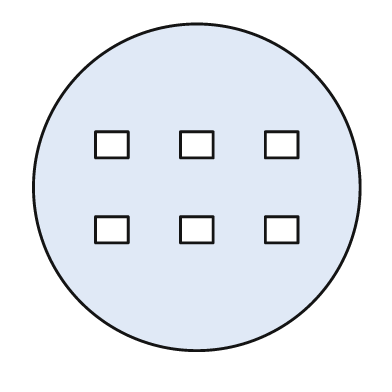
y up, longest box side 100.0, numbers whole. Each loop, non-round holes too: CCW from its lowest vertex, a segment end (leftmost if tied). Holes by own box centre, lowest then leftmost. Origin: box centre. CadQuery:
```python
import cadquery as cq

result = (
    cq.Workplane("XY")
    .moveTo(0.0, 0.0)
    .circle(50.0)
    .moveTo(-31.0, -17.0)
    .lineTo(-21.0, -17.0)
    .lineTo(-21.0, -9.0)
    .lineTo(-31.0, -9.0)
    .close()
    .moveTo(-5.0, -17.0)
    .lineTo(5.0, -17.0)
    .lineTo(5.0, -9.0)
    .lineTo(-5.0, -9.0)
    .close()
    .moveTo(21.0, -17.0)
    .lineTo(31.0, -17.0)
    .lineTo(31.0, -9.0)
    .lineTo(21.0, -9.0)
    .close()
    .moveTo(-31.0, 9.0)
    .lineTo(-21.0, 9.0)
    .lineTo(-21.0, 17.0)
    .lineTo(-31.0, 17.0)
    .close()
    .moveTo(-5.0, 9.0)
    .lineTo(5.0, 9.0)
    .lineTo(5.0, 17.0)
    .lineTo(-5.0, 17.0)
    .close()
    .moveTo(21.0, 9.0)
    .lineTo(31.0, 9.0)
    .lineTo(31.0, 17.0)
    .lineTo(21.0, 17.0)
    .close()
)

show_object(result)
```